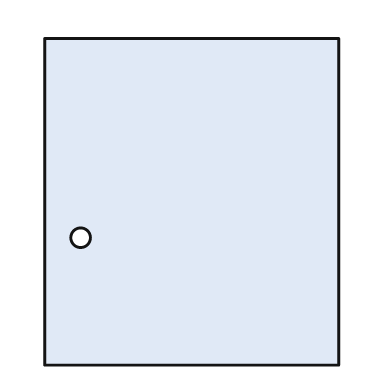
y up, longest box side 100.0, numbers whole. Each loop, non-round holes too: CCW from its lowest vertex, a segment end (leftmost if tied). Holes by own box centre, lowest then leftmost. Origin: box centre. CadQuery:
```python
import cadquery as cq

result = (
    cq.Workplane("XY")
    .moveTo(-45.0, -50.0)
    .lineTo(45.0, -50.0)
    .lineTo(45.0, 50.0)
    .lineTo(-45.0, 50.0)
    .close()
    .moveTo(-34.0, -11.0)
    .circle(3.0)
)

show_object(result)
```